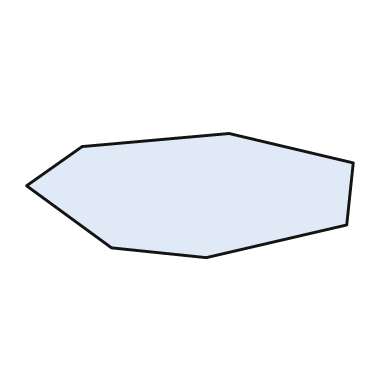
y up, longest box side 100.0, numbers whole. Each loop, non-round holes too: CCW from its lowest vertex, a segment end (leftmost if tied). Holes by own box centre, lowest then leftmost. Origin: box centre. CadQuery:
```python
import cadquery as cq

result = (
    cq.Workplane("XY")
    .moveTo(5.0, -19.0)
    .lineTo(48.0, -9.0)
    .lineTo(50.0, 10.0)
    .lineTo(12.0, 19.0)
    .lineTo(-33.0, 15.0)
    .lineTo(-50.0, 3.0)
    .lineTo(-24.0, -16.0)
    .close()
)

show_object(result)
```